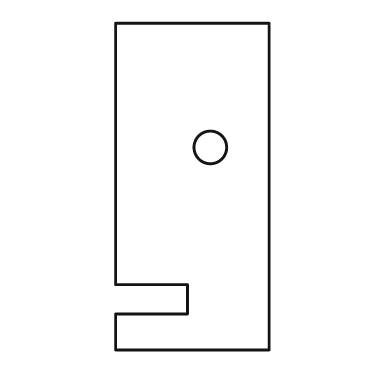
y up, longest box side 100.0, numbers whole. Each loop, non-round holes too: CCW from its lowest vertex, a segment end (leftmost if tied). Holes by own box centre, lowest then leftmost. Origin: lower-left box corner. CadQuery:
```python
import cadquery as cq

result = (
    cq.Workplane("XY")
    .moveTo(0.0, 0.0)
    .lineTo(47.0, 0.0)
    .lineTo(47.0, 100.0)
    .lineTo(0.0, 100.0)
    .lineTo(0.0, 20.0)
    .lineTo(22.0, 20.0)
    .lineTo(22.0, 11.0)
    .lineTo(0.0, 11.0)
    .close()
    .moveTo(29.0, 62.0)
    .circle(5.0)
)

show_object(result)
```